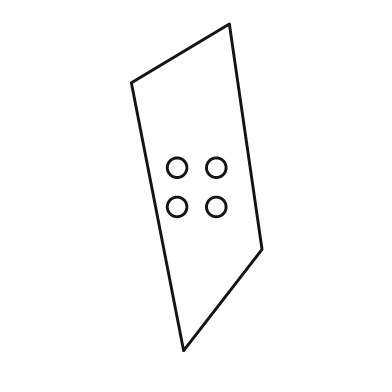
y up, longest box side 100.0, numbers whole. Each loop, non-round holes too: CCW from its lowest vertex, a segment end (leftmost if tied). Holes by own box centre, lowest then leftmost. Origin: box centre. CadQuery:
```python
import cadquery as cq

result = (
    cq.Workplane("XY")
    .moveTo(-4.0, -50.0)
    .lineTo(20.0, -19.0)
    .lineTo(10.0, 50.0)
    .lineTo(-20.0, 32.0)
    .close()
    .moveTo(-6.0, -6.0)
    .circle(3.0)
    .moveTo(6.0, -6.0)
    .circle(3.0)
    .moveTo(-6.0, 6.0)
    .circle(3.0)
    .moveTo(6.0, 6.0)
    .circle(3.0)
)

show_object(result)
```